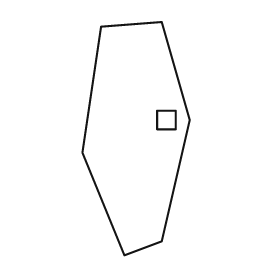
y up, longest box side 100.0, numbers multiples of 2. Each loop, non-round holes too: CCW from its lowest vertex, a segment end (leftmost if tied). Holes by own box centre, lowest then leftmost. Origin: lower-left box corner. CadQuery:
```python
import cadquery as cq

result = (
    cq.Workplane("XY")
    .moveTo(18.0, 0.0)
    .lineTo(34.0, 6.0)
    .lineTo(46.0, 58.0)
    .lineTo(34.0, 100.0)
    .lineTo(8.0, 98.0)
    .lineTo(0.0, 44.0)
    .close()
    .moveTo(32.0, 54.0)
    .lineTo(40.0, 54.0)
    .lineTo(40.0, 62.0)
    .lineTo(32.0, 62.0)
    .close()
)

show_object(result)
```